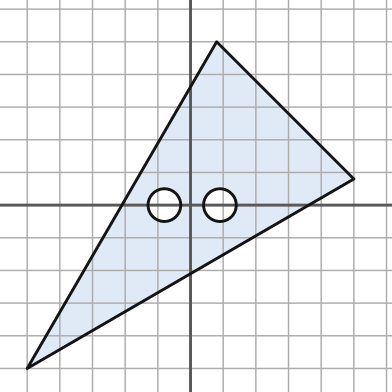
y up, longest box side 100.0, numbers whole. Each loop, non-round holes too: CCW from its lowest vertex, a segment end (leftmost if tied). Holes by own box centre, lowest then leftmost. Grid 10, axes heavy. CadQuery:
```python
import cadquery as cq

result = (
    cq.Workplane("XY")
    .moveTo(-50.0, -50.0)
    .lineTo(50.0, 8.0)
    .lineTo(8.0, 50.0)
    .close()
    .moveTo(-8.0, 0.0)
    .circle(5.0)
    .moveTo(9.0, 0.0)
    .circle(5.0)
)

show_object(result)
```